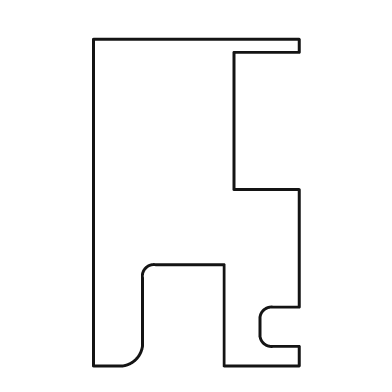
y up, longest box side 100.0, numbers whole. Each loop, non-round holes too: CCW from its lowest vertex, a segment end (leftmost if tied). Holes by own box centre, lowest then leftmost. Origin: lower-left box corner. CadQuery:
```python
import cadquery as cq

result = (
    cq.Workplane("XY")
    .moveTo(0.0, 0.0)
    .lineTo(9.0, 0.0)
    .threePointArc((13.0, 2.0), (15.0, 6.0))
    .lineTo(15.0, 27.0)
    .threePointArc((16.0, 30.0), (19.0, 31.0))
    .lineTo(40.0, 31.0)
    .lineTo(40.0, 0.0)
    .lineTo(63.0, 0.0)
    .lineTo(63.0, 6.0)
    .lineTo(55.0, 6.0)
    .threePointArc((52.0, 7.0), (51.0, 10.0))
    .lineTo(51.0, 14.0)
    .threePointArc((52.0, 17.0), (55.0, 18.0))
    .lineTo(63.0, 18.0)
    .lineTo(63.0, 54.0)
    .lineTo(43.0, 54.0)
    .lineTo(43.0, 96.0)
    .lineTo(63.0, 96.0)
    .lineTo(63.0, 100.0)
    .lineTo(0.0, 100.0)
    .close()
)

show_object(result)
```